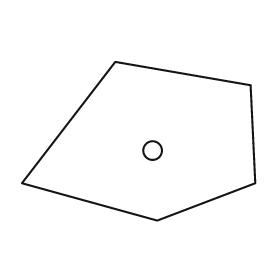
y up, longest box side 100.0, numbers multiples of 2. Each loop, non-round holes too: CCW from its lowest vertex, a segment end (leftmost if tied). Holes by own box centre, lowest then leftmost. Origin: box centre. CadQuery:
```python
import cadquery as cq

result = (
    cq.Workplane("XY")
    .moveTo(8.0, -34.0)
    .lineTo(50.0, -18.0)
    .lineTo(48.0, 24.0)
    .lineTo(-10.0, 34.0)
    .lineTo(-50.0, -18.0)
    .close()
    .moveTo(6.0, -4.0)
    .circle(4.0)
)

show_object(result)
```